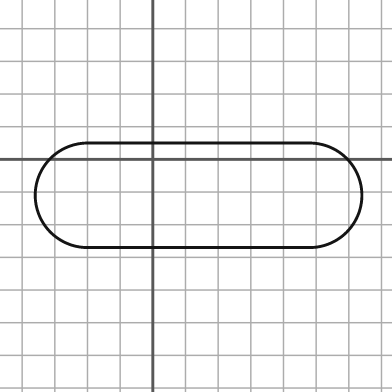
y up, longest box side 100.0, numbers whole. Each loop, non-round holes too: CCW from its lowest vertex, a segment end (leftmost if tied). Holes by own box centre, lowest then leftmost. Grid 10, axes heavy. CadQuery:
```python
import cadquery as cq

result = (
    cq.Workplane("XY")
    .moveTo(-20.0, -27.0)
    .lineTo(48.0, -27.0)
    .threePointArc((64.0, -11.0), (48.0, 5.0))
    .lineTo(-20.0, 5.0)
    .threePointArc((-36.0, -11.0), (-20.0, -27.0))
    .close()
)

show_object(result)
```